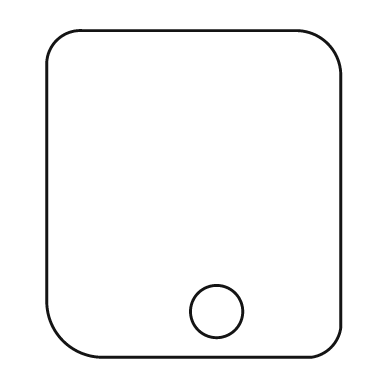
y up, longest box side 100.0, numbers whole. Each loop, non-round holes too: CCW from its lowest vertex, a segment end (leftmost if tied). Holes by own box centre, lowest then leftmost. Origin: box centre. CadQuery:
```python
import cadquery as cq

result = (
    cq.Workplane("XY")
    .moveTo(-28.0, -50.0)
    .lineTo(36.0, -50.0)
    .threePointArc((42.0, -47.0), (45.0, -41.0))
    .lineTo(45.0, 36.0)
    .threePointArc((41.0, 46.0), (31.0, 50.0))
    .lineTo(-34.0, 50.0)
    .threePointArc((-42.0, 47.0), (-45.0, 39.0))
    .lineTo(-45.0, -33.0)
    .threePointArc((-40.0, -45.0), (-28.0, -50.0))
    .close()
    .moveTo(7.0, -36.0)
    .circle(8.0)
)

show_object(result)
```